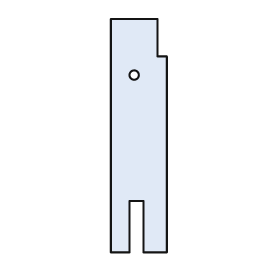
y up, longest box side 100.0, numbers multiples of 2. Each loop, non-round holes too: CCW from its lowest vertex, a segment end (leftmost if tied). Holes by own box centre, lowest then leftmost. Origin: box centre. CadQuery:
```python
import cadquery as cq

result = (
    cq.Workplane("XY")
    .moveTo(-12.0, -50.0)
    .lineTo(-4.0, -50.0)
    .lineTo(-4.0, -28.0)
    .lineTo(2.0, -28.0)
    .lineTo(2.0, -50.0)
    .lineTo(12.0, -50.0)
    .lineTo(12.0, 34.0)
    .lineTo(8.0, 34.0)
    .lineTo(8.0, 50.0)
    .lineTo(-12.0, 50.0)
    .close()
    .moveTo(-2.0, 26.0)
    .circle(2.0)
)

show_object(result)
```